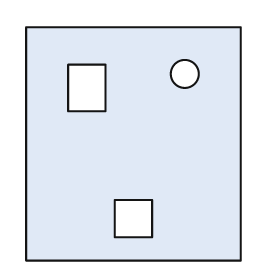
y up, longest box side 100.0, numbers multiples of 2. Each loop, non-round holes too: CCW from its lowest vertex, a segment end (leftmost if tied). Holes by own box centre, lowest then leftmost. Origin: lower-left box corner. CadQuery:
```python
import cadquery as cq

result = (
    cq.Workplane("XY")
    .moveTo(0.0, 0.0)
    .lineTo(92.0, 0.0)
    .lineTo(92.0, 100.0)
    .lineTo(0.0, 100.0)
    .close()
    .moveTo(38.0, 10.0)
    .lineTo(54.0, 10.0)
    .lineTo(54.0, 26.0)
    .lineTo(38.0, 26.0)
    .close()
    .moveTo(18.0, 64.0)
    .lineTo(34.0, 64.0)
    .lineTo(34.0, 84.0)
    .lineTo(18.0, 84.0)
    .close()
    .moveTo(68.0, 80.0)
    .circle(6.0)
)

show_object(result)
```